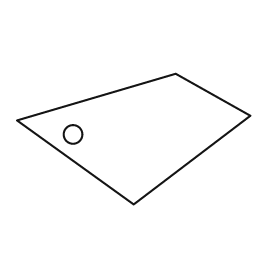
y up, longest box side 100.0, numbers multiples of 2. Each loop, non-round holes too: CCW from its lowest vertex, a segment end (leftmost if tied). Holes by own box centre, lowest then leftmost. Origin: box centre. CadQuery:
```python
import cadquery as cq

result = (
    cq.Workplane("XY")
    .moveTo(0.0, -28.0)
    .lineTo(50.0, 10.0)
    .lineTo(18.0, 28.0)
    .lineTo(-50.0, 8.0)
    .close()
    .moveTo(-26.0, 2.0)
    .circle(4.0)
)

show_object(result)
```